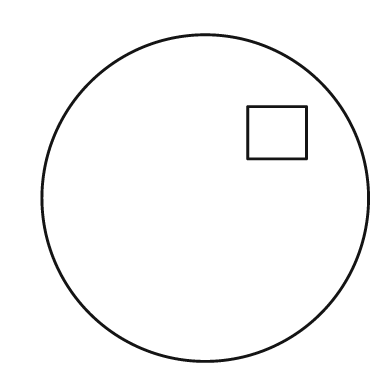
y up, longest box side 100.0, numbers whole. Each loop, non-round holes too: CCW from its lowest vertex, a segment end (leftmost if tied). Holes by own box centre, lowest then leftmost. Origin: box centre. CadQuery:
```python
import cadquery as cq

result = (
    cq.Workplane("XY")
    .moveTo(0.0, 0.0)
    .circle(50.0)
    .moveTo(13.0, 12.0)
    .lineTo(31.0, 12.0)
    .lineTo(31.0, 28.0)
    .lineTo(13.0, 28.0)
    .close()
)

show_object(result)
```